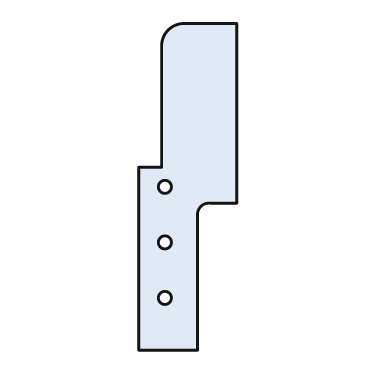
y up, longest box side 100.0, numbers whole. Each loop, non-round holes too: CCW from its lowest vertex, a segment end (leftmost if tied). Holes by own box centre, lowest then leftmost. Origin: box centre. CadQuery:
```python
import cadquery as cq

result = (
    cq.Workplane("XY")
    .moveTo(-15.0, -50.0)
    .lineTo(3.0, -50.0)
    .lineTo(3.0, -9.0)
    .threePointArc((4.0, -6.0), (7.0, -5.0))
    .lineTo(15.0, -5.0)
    .lineTo(15.0, 50.0)
    .lineTo(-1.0, 50.0)
    .threePointArc((-6.0, 48.0), (-8.0, 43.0))
    .lineTo(-8.0, 6.0)
    .lineTo(-15.0, 6.0)
    .close()
    .moveTo(-7.0, -34.0)
    .circle(2.0)
    .moveTo(-7.0, -17.0)
    .circle(2.0)
    .moveTo(-7.0, 0.0)
    .circle(2.0)
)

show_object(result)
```